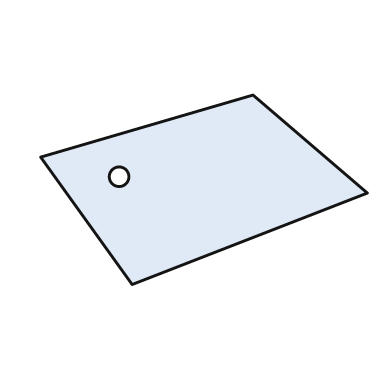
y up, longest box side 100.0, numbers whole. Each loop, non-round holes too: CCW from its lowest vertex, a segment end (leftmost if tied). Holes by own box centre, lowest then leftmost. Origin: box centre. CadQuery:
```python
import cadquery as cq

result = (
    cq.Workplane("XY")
    .moveTo(-22.0, -29.0)
    .lineTo(50.0, -1.0)
    .lineTo(15.0, 29.0)
    .lineTo(-50.0, 10.0)
    .close()
    .moveTo(-26.0, 4.0)
    .circle(3.0)
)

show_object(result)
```